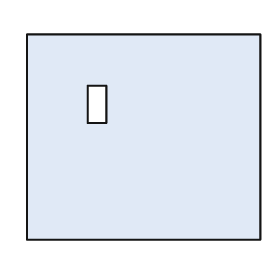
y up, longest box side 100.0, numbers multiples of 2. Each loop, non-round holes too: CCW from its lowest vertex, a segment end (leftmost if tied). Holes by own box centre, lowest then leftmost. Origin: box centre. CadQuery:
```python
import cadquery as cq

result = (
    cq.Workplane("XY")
    .moveTo(-50.0, -44.0)
    .lineTo(50.0, -44.0)
    .lineTo(50.0, 44.0)
    .lineTo(-50.0, 44.0)
    .close()
    .moveTo(-24.0, 6.0)
    .lineTo(-16.0, 6.0)
    .lineTo(-16.0, 22.0)
    .lineTo(-24.0, 22.0)
    .close()
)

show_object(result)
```